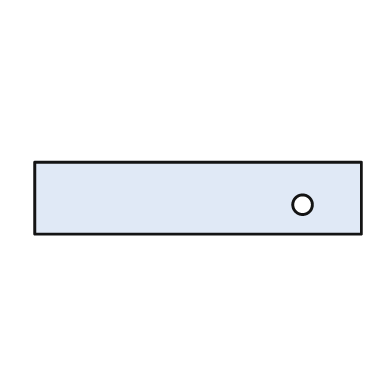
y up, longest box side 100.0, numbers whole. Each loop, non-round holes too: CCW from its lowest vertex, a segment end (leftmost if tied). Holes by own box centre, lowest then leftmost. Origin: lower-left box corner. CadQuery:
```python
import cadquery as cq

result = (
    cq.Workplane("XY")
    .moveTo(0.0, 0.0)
    .lineTo(100.0, 0.0)
    .lineTo(100.0, 22.0)
    .lineTo(0.0, 22.0)
    .close()
    .moveTo(82.0, 9.0)
    .circle(3.0)
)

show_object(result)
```